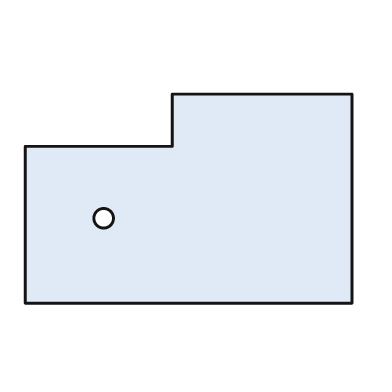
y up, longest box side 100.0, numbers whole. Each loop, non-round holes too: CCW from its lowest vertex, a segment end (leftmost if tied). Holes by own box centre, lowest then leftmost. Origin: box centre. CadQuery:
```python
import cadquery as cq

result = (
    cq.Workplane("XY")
    .moveTo(-50.0, -32.0)
    .lineTo(50.0, -32.0)
    .lineTo(50.0, 32.0)
    .lineTo(-5.0, 32.0)
    .lineTo(-5.0, 16.0)
    .lineTo(-50.0, 16.0)
    .close()
    .moveTo(-26.0, -6.0)
    .circle(3.0)
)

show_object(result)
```